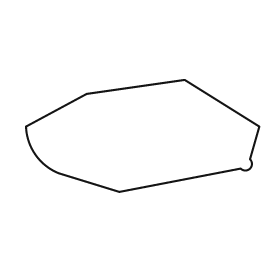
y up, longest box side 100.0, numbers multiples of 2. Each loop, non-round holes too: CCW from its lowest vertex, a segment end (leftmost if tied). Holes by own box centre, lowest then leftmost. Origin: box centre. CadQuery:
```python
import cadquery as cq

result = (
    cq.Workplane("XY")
    .moveTo(-10.0, -24.0)
    .lineTo(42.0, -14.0)
    .threePointArc((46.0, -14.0), (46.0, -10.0))
    .lineTo(50.0, 4.0)
    .lineTo(18.0, 24.0)
    .lineTo(-24.0, 18.0)
    .lineTo(-50.0, 4.0)
    .threePointArc((-46.0, -8.0), (-36.0, -16.0))
    .close()
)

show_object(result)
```